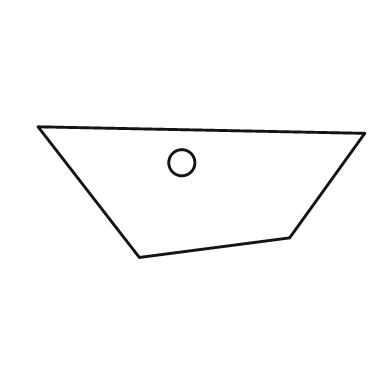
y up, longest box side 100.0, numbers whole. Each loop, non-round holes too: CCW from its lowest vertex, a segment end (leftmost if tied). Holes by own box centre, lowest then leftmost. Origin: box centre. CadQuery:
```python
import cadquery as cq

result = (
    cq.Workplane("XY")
    .moveTo(-19.0, -20.0)
    .lineTo(27.0, -14.0)
    .lineTo(50.0, 18.0)
    .lineTo(-50.0, 20.0)
    .close()
    .moveTo(-6.0, 9.0)
    .circle(4.0)
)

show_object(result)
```